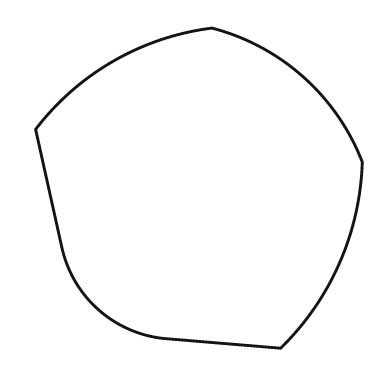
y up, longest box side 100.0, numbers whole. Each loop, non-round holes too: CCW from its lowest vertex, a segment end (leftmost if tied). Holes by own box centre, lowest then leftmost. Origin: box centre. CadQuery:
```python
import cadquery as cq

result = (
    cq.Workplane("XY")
    .moveTo(25.0, -49.0)
    .threePointArc((43.0, -23.0), (50.0, 8.0))
    .threePointArc((32.0, 34.0), (4.0, 49.0))
    .threePointArc((-26.0, 39.0), (-50.0, 18.0))
    .lineTo(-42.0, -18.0)
    .threePointArc((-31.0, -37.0), (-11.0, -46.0))
    .close()
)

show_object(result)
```